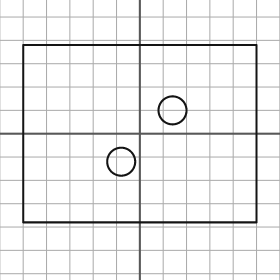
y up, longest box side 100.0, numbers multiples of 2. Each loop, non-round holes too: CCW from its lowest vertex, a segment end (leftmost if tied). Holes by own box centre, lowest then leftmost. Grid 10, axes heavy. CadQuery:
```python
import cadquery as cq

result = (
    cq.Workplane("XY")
    .moveTo(-50.0, -38.0)
    .lineTo(50.0, -38.0)
    .lineTo(50.0, 38.0)
    .lineTo(-50.0, 38.0)
    .close()
    .moveTo(-8.0, -12.0)
    .circle(6.0)
    .moveTo(14.0, 10.0)
    .circle(6.0)
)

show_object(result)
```